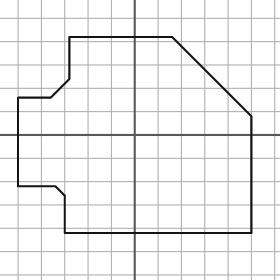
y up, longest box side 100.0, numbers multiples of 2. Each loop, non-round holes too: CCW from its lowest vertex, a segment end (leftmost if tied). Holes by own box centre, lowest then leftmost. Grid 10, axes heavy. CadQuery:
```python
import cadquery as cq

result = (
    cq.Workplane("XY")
    .moveTo(-30.0, -42.0)
    .lineTo(50.0, -42.0)
    .lineTo(50.0, 8.0)
    .lineTo(16.0, 42.0)
    .lineTo(-28.0, 42.0)
    .lineTo(-28.0, 24.0)
    .lineTo(-36.0, 16.0)
    .lineTo(-50.0, 16.0)
    .lineTo(-50.0, -22.0)
    .lineTo(-34.0, -22.0)
    .lineTo(-30.0, -26.0)
    .close()
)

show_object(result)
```